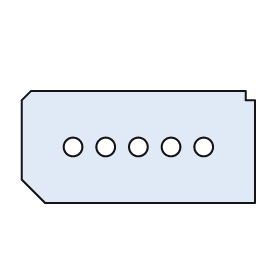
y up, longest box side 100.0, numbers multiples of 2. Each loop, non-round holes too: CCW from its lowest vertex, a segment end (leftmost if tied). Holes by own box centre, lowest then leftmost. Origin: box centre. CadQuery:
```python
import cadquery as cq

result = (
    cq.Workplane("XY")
    .moveTo(-40.0, -24.0)
    .lineTo(50.0, -24.0)
    .lineTo(50.0, 20.0)
    .lineTo(46.0, 20.0)
    .lineTo(46.0, 24.0)
    .lineTo(-46.0, 24.0)
    .lineTo(-50.0, 20.0)
    .lineTo(-50.0, -14.0)
    .close()
    .moveTo(-28.0, 0.0)
    .circle(4.0)
    .moveTo(-14.0, 0.0)
    .circle(4.0)
    .moveTo(0.0, 0.0)
    .circle(4.0)
    .moveTo(14.0, 0.0)
    .circle(4.0)
    .moveTo(28.0, 0.0)
    .circle(4.0)
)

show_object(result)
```